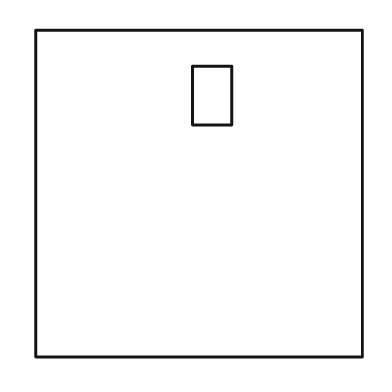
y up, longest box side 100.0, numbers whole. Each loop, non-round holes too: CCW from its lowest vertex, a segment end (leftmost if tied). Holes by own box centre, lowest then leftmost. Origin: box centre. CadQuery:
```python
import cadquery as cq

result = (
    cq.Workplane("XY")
    .moveTo(-50.0, -50.0)
    .lineTo(50.0, -50.0)
    .lineTo(50.0, 50.0)
    .lineTo(-50.0, 50.0)
    .close()
    .moveTo(-2.0, 21.0)
    .lineTo(10.0, 21.0)
    .lineTo(10.0, 39.0)
    .lineTo(-2.0, 39.0)
    .close()
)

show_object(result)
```